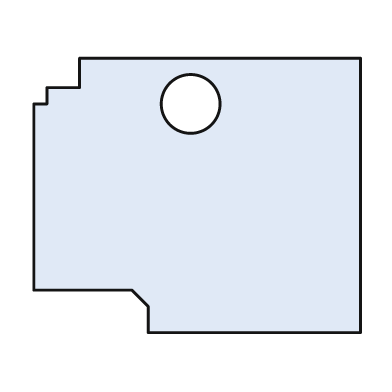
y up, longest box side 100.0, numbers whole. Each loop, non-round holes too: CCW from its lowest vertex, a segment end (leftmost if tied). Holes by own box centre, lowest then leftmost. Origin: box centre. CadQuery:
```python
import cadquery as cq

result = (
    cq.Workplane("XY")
    .moveTo(-15.0, -42.0)
    .lineTo(50.0, -42.0)
    .lineTo(50.0, 42.0)
    .lineTo(-36.0, 42.0)
    .lineTo(-36.0, 33.0)
    .lineTo(-46.0, 33.0)
    .lineTo(-46.0, 28.0)
    .lineTo(-50.0, 28.0)
    .lineTo(-50.0, -29.0)
    .lineTo(-20.0, -29.0)
    .lineTo(-15.0, -34.0)
    .close()
    .moveTo(-2.0, 28.0)
    .circle(9.0)
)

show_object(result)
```